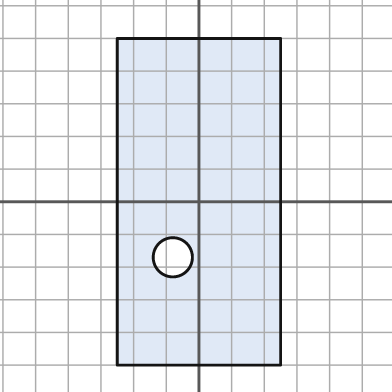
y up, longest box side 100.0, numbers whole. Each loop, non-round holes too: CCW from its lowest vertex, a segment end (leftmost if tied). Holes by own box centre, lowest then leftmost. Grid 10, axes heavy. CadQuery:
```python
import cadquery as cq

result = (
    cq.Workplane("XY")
    .moveTo(-25.0, -50.0)
    .lineTo(25.0, -50.0)
    .lineTo(25.0, 50.0)
    .lineTo(-25.0, 50.0)
    .close()
    .moveTo(-8.0, -17.0)
    .circle(6.0)
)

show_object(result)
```